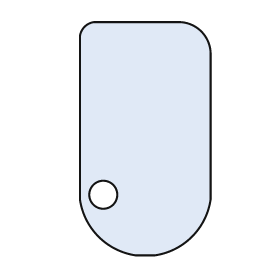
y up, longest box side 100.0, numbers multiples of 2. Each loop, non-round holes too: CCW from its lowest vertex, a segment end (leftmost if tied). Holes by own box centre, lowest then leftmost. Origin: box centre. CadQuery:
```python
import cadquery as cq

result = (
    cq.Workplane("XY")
    .moveTo(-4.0, -50.0)
    .lineTo(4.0, -50.0)
    .threePointArc((20.0, -42.0), (28.0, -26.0))
    .lineTo(28.0, 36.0)
    .threePointArc((24.0, 46.0), (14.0, 50.0))
    .lineTo(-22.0, 50.0)
    .threePointArc((-26.0, 48.0), (-28.0, 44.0))
    .lineTo(-28.0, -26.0)
    .threePointArc((-20.0, -42.0), (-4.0, -50.0))
    .close()
    .moveTo(-18.0, -24.0)
    .circle(6.0)
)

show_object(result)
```